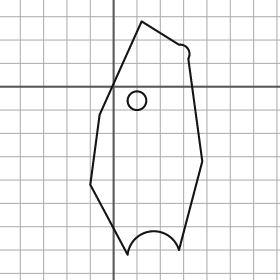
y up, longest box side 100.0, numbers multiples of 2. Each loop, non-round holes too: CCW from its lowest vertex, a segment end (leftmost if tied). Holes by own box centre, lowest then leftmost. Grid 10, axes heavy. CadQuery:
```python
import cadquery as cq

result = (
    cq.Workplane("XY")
    .moveTo(6.0, -72.0)
    .threePointArc((16.0, -62.0), (28.0, -70.0))
    .lineTo(38.0, -32.0)
    .lineTo(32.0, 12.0)
    .threePointArc((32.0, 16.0), (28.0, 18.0))
    .lineTo(12.0, 28.0)
    .lineTo(-6.0, -12.0)
    .lineTo(-10.0, -42.0)
    .close()
    .moveTo(10.0, -6.0)
    .circle(4.0)
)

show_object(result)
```